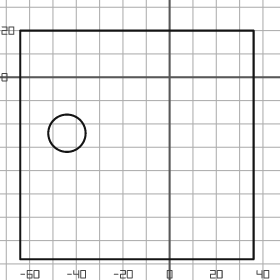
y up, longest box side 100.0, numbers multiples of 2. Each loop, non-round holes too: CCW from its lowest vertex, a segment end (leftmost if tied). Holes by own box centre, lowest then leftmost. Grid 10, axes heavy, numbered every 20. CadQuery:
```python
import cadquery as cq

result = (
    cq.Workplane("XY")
    .moveTo(-64.0, -78.0)
    .lineTo(36.0, -78.0)
    .lineTo(36.0, 20.0)
    .lineTo(-64.0, 20.0)
    .close()
    .moveTo(-44.0, -24.0)
    .circle(8.0)
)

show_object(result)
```